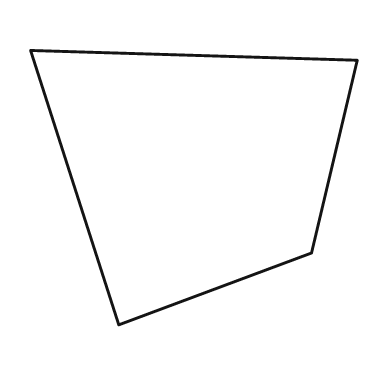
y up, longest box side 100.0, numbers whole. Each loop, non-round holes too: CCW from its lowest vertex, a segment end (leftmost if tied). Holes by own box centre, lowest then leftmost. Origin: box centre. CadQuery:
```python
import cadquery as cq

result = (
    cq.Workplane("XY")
    .moveTo(-23.0, -42.0)
    .lineTo(36.0, -20.0)
    .lineTo(50.0, 39.0)
    .lineTo(-50.0, 42.0)
    .close()
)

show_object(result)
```